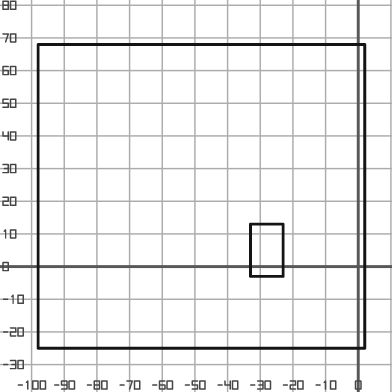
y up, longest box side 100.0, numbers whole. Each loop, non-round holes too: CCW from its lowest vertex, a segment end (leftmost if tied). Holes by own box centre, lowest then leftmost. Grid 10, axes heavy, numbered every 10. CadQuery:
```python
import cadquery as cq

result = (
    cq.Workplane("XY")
    .moveTo(-98.0, -25.0)
    .lineTo(2.0, -25.0)
    .lineTo(2.0, 68.0)
    .lineTo(-98.0, 68.0)
    .close()
    .moveTo(-33.0, -3.0)
    .lineTo(-23.0, -3.0)
    .lineTo(-23.0, 13.0)
    .lineTo(-33.0, 13.0)
    .close()
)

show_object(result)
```